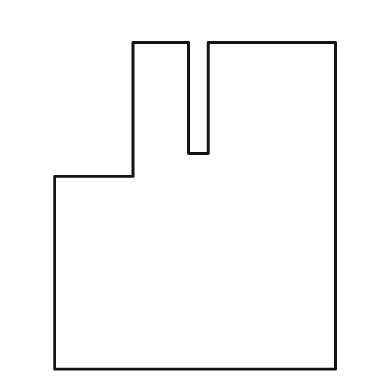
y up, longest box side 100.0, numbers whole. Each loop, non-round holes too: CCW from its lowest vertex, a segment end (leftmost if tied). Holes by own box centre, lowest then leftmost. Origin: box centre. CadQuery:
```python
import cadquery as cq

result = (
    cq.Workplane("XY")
    .moveTo(-43.0, -50.0)
    .lineTo(43.0, -50.0)
    .lineTo(43.0, 50.0)
    .lineTo(4.0, 50.0)
    .lineTo(4.0, 16.0)
    .lineTo(-2.0, 16.0)
    .lineTo(-2.0, 50.0)
    .lineTo(-19.0, 50.0)
    .lineTo(-19.0, 9.0)
    .lineTo(-43.0, 9.0)
    .close()
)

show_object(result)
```